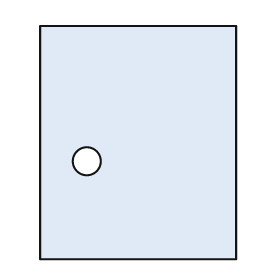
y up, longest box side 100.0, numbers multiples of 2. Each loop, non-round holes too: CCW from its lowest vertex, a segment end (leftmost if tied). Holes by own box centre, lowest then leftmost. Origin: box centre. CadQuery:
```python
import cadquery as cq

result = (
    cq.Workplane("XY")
    .moveTo(-42.0, -50.0)
    .lineTo(42.0, -50.0)
    .lineTo(42.0, 50.0)
    .lineTo(-42.0, 50.0)
    .close()
    .moveTo(-22.0, -8.0)
    .circle(6.0)
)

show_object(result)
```